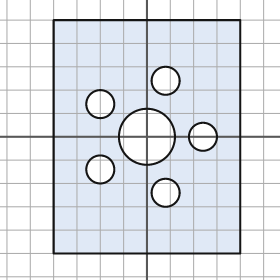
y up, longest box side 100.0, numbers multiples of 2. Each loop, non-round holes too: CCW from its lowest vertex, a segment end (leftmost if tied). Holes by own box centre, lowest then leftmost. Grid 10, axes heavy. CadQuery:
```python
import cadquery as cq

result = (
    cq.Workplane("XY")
    .moveTo(-40.0, -50.0)
    .lineTo(40.0, -50.0)
    .lineTo(40.0, 50.0)
    .lineTo(-40.0, 50.0)
    .close()
    .moveTo(8.0, -24.0)
    .circle(6.0)
    .moveTo(-20.0, -14.0)
    .circle(6.0)
    .moveTo(0.0, 0.0)
    .circle(12.0)
    .moveTo(24.0, 0.0)
    .circle(6.0)
    .moveTo(-20.0, 14.0)
    .circle(6.0)
    .moveTo(8.0, 24.0)
    .circle(6.0)
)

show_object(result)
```